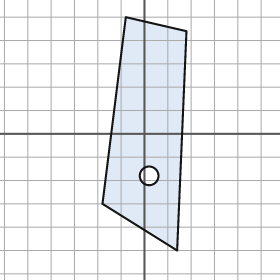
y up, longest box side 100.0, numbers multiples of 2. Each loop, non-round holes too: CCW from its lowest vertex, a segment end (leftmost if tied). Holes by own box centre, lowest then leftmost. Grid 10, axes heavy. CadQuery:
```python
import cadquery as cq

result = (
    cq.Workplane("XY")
    .moveTo(14.0, -50.0)
    .lineTo(18.0, 44.0)
    .lineTo(-8.0, 50.0)
    .lineTo(-18.0, -30.0)
    .close()
    .moveTo(2.0, -18.0)
    .circle(4.0)
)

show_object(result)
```